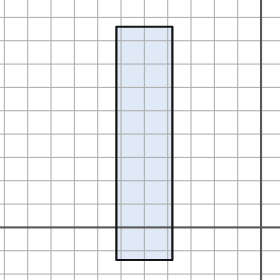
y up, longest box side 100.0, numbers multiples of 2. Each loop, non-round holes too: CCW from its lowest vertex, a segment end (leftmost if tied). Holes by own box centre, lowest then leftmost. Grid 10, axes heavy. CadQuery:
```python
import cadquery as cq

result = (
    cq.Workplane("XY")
    .moveTo(-62.0, -14.0)
    .lineTo(-38.0, -14.0)
    .lineTo(-38.0, 86.0)
    .lineTo(-62.0, 86.0)
    .close()
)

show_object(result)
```